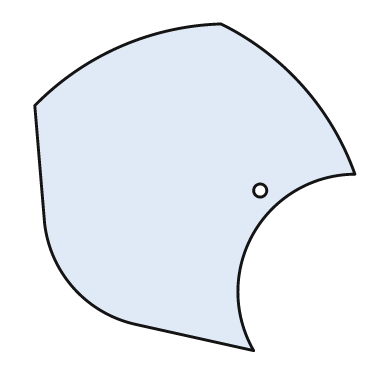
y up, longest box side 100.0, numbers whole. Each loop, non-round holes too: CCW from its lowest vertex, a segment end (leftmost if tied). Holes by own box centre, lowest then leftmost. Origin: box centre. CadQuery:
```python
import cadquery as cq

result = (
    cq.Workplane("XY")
    .moveTo(18.0, -50.0)
    .threePointArc((18.0, -14.0), (49.0, 4.0))
    .threePointArc((33.0, 31.0), (8.0, 50.0))
    .threePointArc((-23.0, 43.0), (-49.0, 25.0))
    .lineTo(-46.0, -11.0)
    .threePointArc((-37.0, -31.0), (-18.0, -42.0))
    .close()
    .moveTo(20.0, -1.0)
    .circle(2.0)
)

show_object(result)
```